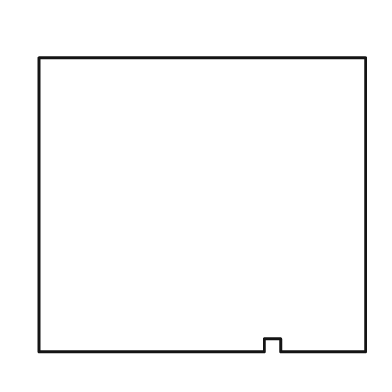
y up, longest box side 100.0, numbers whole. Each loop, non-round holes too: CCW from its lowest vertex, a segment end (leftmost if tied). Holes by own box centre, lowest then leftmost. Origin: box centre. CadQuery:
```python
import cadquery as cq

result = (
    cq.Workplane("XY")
    .moveTo(-50.0, -45.0)
    .lineTo(19.0, -45.0)
    .lineTo(19.0, -41.0)
    .lineTo(24.0, -41.0)
    .lineTo(24.0, -45.0)
    .lineTo(50.0, -45.0)
    .lineTo(50.0, 45.0)
    .lineTo(-50.0, 45.0)
    .close()
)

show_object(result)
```